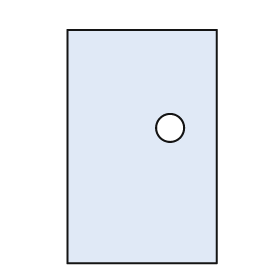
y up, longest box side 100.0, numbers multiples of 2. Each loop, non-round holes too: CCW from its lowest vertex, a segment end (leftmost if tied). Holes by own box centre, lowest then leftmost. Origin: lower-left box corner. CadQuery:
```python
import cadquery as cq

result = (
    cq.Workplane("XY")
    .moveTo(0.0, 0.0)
    .lineTo(64.0, 0.0)
    .lineTo(64.0, 100.0)
    .lineTo(0.0, 100.0)
    .close()
    .moveTo(44.0, 58.0)
    .circle(6.0)
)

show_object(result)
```